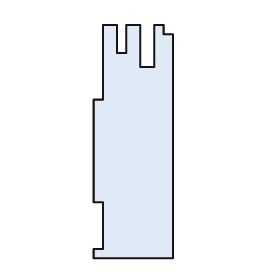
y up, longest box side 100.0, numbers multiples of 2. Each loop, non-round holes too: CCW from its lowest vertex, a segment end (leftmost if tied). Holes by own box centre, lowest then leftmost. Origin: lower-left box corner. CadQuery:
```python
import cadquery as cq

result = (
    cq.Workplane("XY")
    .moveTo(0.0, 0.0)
    .lineTo(34.0, 0.0)
    .lineTo(34.0, 96.0)
    .lineTo(30.0, 96.0)
    .lineTo(30.0, 100.0)
    .lineTo(26.0, 100.0)
    .lineTo(26.0, 82.0)
    .lineTo(20.0, 82.0)
    .lineTo(20.0, 100.0)
    .lineTo(14.0, 100.0)
    .lineTo(14.0, 88.0)
    .lineTo(10.0, 88.0)
    .lineTo(10.0, 100.0)
    .lineTo(4.0, 100.0)
    .lineTo(4.0, 68.0)
    .lineTo(0.0, 68.0)
    .lineTo(0.0, 24.0)
    .lineTo(4.0, 24.0)
    .lineTo(4.0, 4.0)
    .lineTo(0.0, 4.0)
    .close()
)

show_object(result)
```